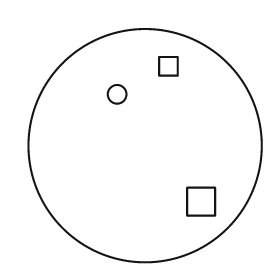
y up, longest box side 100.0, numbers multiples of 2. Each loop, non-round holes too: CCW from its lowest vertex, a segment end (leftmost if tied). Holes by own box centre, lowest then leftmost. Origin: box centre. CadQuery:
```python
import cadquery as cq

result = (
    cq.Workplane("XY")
    .moveTo(0.0, 0.0)
    .circle(50.0)
    .moveTo(18.0, -30.0)
    .lineTo(30.0, -30.0)
    .lineTo(30.0, -18.0)
    .lineTo(18.0, -18.0)
    .close()
    .moveTo(-12.0, 22.0)
    .circle(4.0)
    .moveTo(6.0, 30.0)
    .lineTo(14.0, 30.0)
    .lineTo(14.0, 38.0)
    .lineTo(6.0, 38.0)
    .close()
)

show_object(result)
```